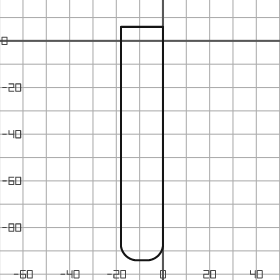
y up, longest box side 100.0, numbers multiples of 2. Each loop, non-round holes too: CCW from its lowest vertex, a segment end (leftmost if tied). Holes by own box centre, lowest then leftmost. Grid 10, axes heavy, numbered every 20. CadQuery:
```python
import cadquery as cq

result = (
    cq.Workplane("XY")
    .moveTo(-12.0, -94.0)
    .lineTo(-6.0, -94.0)
    .threePointArc((-2.0, -92.0), (0.0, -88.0))
    .lineTo(0.0, 6.0)
    .lineTo(-18.0, 6.0)
    .lineTo(-18.0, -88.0)
    .threePointArc((-16.0, -92.0), (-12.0, -94.0))
    .close()
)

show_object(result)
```